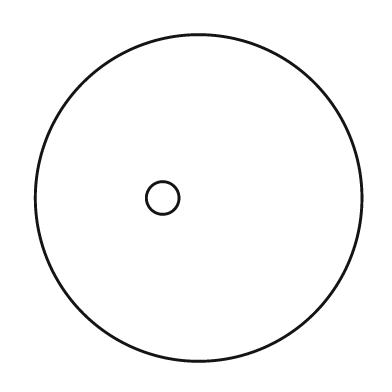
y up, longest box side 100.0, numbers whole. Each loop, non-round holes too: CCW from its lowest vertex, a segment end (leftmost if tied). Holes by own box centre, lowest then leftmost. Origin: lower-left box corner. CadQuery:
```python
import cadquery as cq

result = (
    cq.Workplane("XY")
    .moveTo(50.0, 50.0)
    .circle(50.0)
    .moveTo(39.0, 50.0)
    .circle(5.0)
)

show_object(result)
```